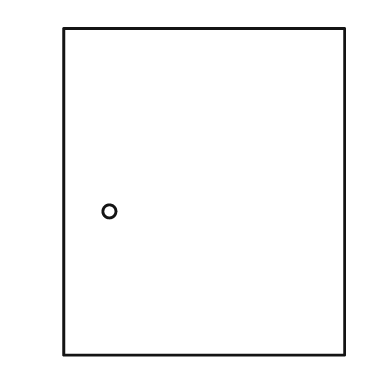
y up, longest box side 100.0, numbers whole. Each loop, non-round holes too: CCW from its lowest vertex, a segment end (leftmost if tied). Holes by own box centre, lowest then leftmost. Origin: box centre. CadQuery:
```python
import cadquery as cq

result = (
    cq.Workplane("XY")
    .moveTo(-43.0, -50.0)
    .lineTo(43.0, -50.0)
    .lineTo(43.0, 50.0)
    .lineTo(-43.0, 50.0)
    .close()
    .moveTo(-29.0, -6.0)
    .circle(2.0)
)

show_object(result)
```